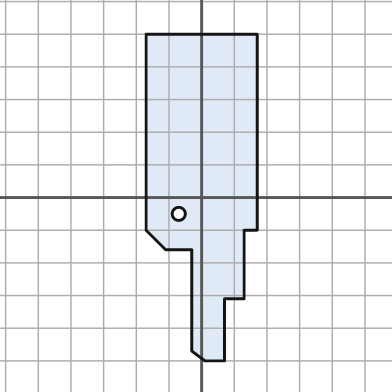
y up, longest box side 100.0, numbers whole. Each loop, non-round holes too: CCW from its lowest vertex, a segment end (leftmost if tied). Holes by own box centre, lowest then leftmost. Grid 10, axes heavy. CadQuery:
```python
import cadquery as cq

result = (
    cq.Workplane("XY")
    .moveTo(1.0, -50.0)
    .lineTo(7.0, -50.0)
    .lineTo(7.0, -31.0)
    .lineTo(13.0, -31.0)
    .lineTo(13.0, -10.0)
    .lineTo(17.0, -10.0)
    .lineTo(17.0, 50.0)
    .lineTo(-17.0, 50.0)
    .lineTo(-17.0, -10.0)
    .lineTo(-11.0, -16.0)
    .lineTo(-3.0, -16.0)
    .lineTo(-3.0, -47.0)
    .close()
    .moveTo(-7.0, -5.0)
    .circle(2.0)
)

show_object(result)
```